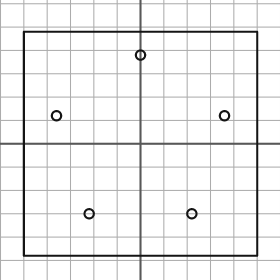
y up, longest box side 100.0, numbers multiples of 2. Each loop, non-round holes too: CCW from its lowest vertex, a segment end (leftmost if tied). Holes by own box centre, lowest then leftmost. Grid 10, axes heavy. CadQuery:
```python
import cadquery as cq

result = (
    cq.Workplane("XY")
    .moveTo(-50.0, -48.0)
    .lineTo(50.0, -48.0)
    .lineTo(50.0, 48.0)
    .lineTo(-50.0, 48.0)
    .close()
    .moveTo(-22.0, -30.0)
    .circle(2.0)
    .moveTo(22.0, -30.0)
    .circle(2.0)
    .moveTo(-36.0, 12.0)
    .circle(2.0)
    .moveTo(36.0, 12.0)
    .circle(2.0)
    .moveTo(0.0, 38.0)
    .circle(2.0)
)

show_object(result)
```